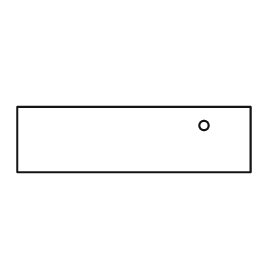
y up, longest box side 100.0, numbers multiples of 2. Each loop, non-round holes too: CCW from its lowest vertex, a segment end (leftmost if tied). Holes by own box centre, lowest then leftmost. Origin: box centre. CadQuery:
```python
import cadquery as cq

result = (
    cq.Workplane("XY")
    .moveTo(-50.0, -14.0)
    .lineTo(50.0, -14.0)
    .lineTo(50.0, 14.0)
    .lineTo(-50.0, 14.0)
    .close()
    .moveTo(30.0, 6.0)
    .circle(2.0)
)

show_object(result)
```